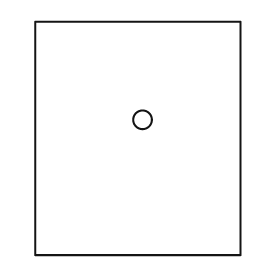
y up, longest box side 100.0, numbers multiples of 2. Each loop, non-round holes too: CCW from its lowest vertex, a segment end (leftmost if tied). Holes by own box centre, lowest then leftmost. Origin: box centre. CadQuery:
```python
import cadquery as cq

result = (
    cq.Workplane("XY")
    .moveTo(-44.0, -50.0)
    .lineTo(44.0, -50.0)
    .lineTo(44.0, 50.0)
    .lineTo(-44.0, 50.0)
    .close()
    .moveTo(2.0, 8.0)
    .circle(4.0)
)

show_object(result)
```